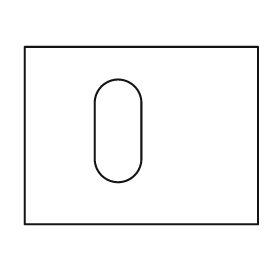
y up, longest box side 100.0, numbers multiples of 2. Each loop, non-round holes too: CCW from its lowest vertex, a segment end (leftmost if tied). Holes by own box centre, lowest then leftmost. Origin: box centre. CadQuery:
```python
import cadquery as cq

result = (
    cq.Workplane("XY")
    .moveTo(-50.0, -38.0)
    .lineTo(50.0, -38.0)
    .lineTo(50.0, 38.0)
    .lineTo(-50.0, 38.0)
    .close()
    .moveTo(-20.0, -10.0)
    .threePointArc((-10.0, -20.0), (0.0, -10.0))
    .lineTo(0.0, 14.0)
    .threePointArc((-10.0, 24.0), (-20.0, 14.0))
    .close()
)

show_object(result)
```